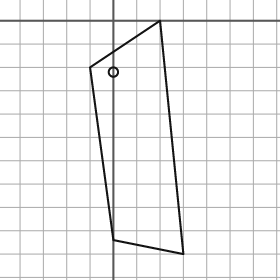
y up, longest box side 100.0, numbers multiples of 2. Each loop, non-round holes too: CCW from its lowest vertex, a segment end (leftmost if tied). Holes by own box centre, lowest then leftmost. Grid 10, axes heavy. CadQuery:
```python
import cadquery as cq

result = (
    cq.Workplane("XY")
    .moveTo(30.0, -100.0)
    .lineTo(20.0, 0.0)
    .lineTo(-10.0, -20.0)
    .lineTo(0.0, -94.0)
    .close()
    .moveTo(0.0, -22.0)
    .circle(2.0)
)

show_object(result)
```